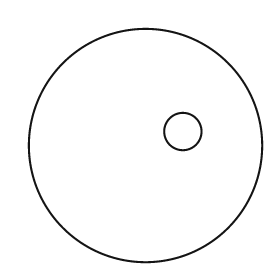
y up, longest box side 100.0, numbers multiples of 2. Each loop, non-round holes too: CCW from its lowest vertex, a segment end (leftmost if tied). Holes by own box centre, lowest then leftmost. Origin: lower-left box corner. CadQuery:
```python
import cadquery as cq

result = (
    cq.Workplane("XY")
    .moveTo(50.0, 50.0)
    .circle(50.0)
    .moveTo(66.0, 56.0)
    .circle(8.0)
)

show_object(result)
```